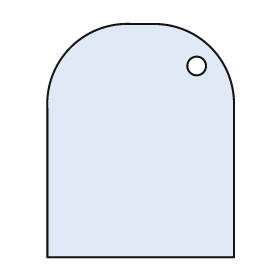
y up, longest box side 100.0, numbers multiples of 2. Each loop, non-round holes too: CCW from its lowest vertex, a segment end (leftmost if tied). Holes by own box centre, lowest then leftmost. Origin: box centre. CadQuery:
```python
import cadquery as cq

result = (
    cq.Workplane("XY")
    .moveTo(-40.0, -50.0)
    .lineTo(40.0, -50.0)
    .lineTo(40.0, 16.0)
    .threePointArc((30.0, 40.0), (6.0, 50.0))
    .lineTo(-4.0, 50.0)
    .threePointArc((-30.0, 40.0), (-40.0, 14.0))
    .close()
    .moveTo(24.0, 32.0)
    .circle(4.0)
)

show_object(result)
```